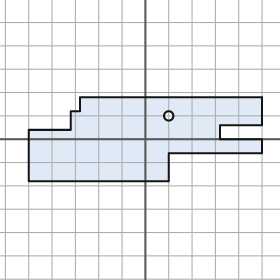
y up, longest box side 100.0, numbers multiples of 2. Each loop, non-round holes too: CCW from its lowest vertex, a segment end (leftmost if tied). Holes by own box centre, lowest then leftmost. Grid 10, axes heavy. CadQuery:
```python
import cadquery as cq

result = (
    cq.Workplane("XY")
    .moveTo(-50.0, -18.0)
    .lineTo(10.0, -18.0)
    .lineTo(10.0, -6.0)
    .lineTo(50.0, -6.0)
    .lineTo(50.0, 0.0)
    .lineTo(32.0, 0.0)
    .lineTo(32.0, 6.0)
    .lineTo(50.0, 6.0)
    .lineTo(50.0, 18.0)
    .lineTo(-28.0, 18.0)
    .lineTo(-28.0, 12.0)
    .lineTo(-32.0, 12.0)
    .lineTo(-32.0, 4.0)
    .lineTo(-50.0, 4.0)
    .close()
    .moveTo(10.0, 10.0)
    .circle(2.0)
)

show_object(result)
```